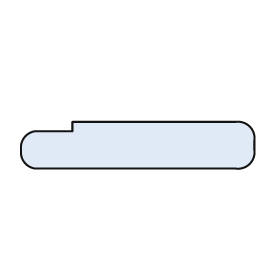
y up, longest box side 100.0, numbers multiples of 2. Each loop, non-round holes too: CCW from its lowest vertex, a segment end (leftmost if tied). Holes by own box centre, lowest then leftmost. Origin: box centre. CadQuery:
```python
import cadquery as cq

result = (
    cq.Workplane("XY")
    .moveTo(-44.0, -10.0)
    .lineTo(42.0, -10.0)
    .threePointArc((48.0, -8.0), (50.0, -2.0))
    .lineTo(50.0, 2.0)
    .threePointArc((48.0, 8.0), (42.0, 10.0))
    .lineTo(-28.0, 10.0)
    .lineTo(-28.0, 6.0)
    .lineTo(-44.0, 6.0)
    .threePointArc((-48.0, 4.0), (-50.0, 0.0))
    .lineTo(-50.0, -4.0)
    .threePointArc((-48.0, -8.0), (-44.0, -10.0))
    .close()
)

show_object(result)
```